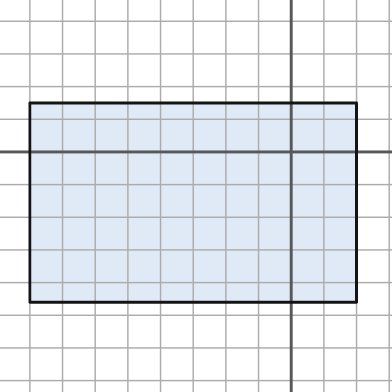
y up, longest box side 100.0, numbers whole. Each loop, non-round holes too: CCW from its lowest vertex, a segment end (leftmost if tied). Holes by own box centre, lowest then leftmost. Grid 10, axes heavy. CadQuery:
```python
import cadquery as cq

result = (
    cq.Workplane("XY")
    .moveTo(-80.0, -46.0)
    .lineTo(20.0, -46.0)
    .lineTo(20.0, 15.0)
    .lineTo(-80.0, 15.0)
    .close()
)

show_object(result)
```